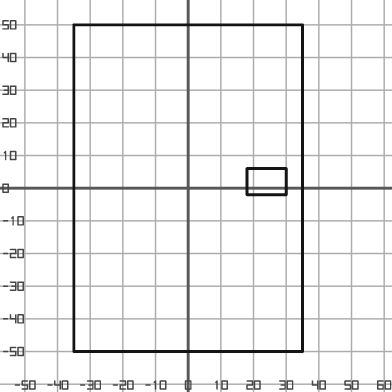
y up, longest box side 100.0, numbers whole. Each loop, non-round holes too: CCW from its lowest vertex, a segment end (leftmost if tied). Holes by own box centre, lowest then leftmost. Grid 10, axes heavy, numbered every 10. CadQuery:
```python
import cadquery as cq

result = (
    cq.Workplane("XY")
    .moveTo(-35.0, -50.0)
    .lineTo(35.0, -50.0)
    .lineTo(35.0, 50.0)
    .lineTo(-35.0, 50.0)
    .close()
    .moveTo(18.0, -2.0)
    .lineTo(30.0, -2.0)
    .lineTo(30.0, 6.0)
    .lineTo(18.0, 6.0)
    .close()
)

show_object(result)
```